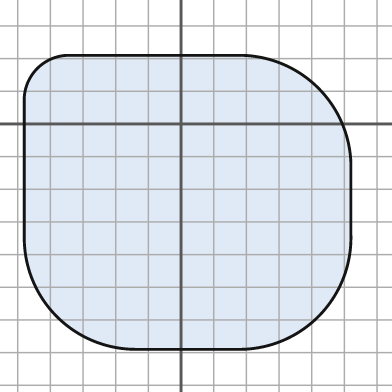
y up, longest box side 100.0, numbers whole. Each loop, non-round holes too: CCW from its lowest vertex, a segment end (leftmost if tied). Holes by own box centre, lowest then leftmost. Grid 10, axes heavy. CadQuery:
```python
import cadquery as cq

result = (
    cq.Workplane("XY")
    .moveTo(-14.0, -69.0)
    .lineTo(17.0, -69.0)
    .threePointArc((42.0, -59.0), (52.0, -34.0))
    .lineTo(52.0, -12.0)
    .threePointArc((42.0, 11.0), (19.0, 21.0))
    .lineTo(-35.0, 21.0)
    .threePointArc((-44.0, 17.0), (-48.0, 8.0))
    .lineTo(-48.0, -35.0)
    .threePointArc((-38.0, -59.0), (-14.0, -69.0))
    .close()
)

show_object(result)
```